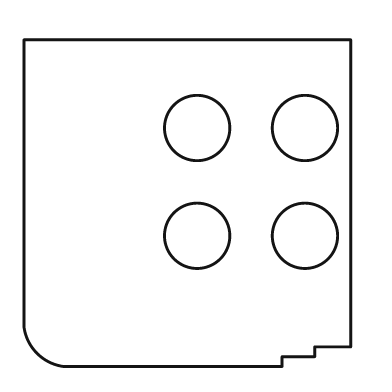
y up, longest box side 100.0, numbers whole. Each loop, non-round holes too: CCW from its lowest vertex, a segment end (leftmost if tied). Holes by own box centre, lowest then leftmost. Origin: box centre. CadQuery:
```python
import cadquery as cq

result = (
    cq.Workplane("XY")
    .moveTo(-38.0, -50.0)
    .lineTo(29.0, -50.0)
    .lineTo(29.0, -47.0)
    .lineTo(39.0, -47.0)
    .lineTo(39.0, -44.0)
    .lineTo(50.0, -44.0)
    .lineTo(50.0, 50.0)
    .lineTo(-50.0, 50.0)
    .lineTo(-50.0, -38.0)
    .threePointArc((-46.0, -46.0), (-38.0, -50.0))
    .close()
    .moveTo(3.0, -10.0)
    .circle(10.0)
    .moveTo(36.0, -10.0)
    .circle(10.0)
    .moveTo(3.0, 23.0)
    .circle(10.0)
    .moveTo(36.0, 23.0)
    .circle(10.0)
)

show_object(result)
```